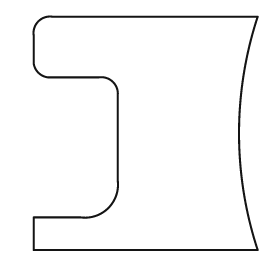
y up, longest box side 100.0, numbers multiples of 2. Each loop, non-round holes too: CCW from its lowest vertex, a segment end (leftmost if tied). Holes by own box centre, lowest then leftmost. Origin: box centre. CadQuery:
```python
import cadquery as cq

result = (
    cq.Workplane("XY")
    .moveTo(-48.0, -50.0)
    .lineTo(48.0, -50.0)
    .threePointArc((40.0, 0.0), (48.0, 50.0))
    .lineTo(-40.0, 50.0)
    .threePointArc((-46.0, 48.0), (-48.0, 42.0))
    .lineTo(-48.0, 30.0)
    .threePointArc((-46.0, 26.0), (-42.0, 24.0))
    .lineTo(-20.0, 24.0)
    .threePointArc((-14.0, 22.0), (-12.0, 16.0))
    .lineTo(-12.0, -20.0)
    .threePointArc((-16.0, -32.0), (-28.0, -36.0))
    .lineTo(-48.0, -36.0)
    .close()
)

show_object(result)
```